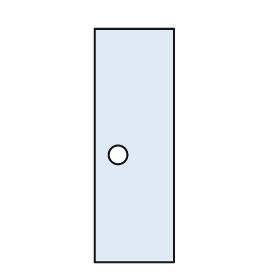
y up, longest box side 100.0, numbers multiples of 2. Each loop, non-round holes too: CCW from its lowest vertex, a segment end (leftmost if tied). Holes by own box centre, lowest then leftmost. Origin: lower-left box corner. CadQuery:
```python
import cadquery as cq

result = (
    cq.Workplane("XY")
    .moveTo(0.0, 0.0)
    .lineTo(34.0, 0.0)
    .lineTo(34.0, 100.0)
    .lineTo(0.0, 100.0)
    .close()
    .moveTo(10.0, 46.0)
    .circle(4.0)
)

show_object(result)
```